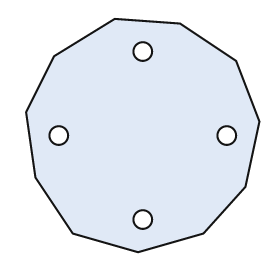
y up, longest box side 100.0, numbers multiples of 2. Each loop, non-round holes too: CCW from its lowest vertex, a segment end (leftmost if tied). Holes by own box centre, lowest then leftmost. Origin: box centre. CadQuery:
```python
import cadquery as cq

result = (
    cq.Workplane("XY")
    .moveTo(-2.0, -50.0)
    .lineTo(26.0, -42.0)
    .lineTo(44.0, -22.0)
    .lineTo(50.0, 6.0)
    .lineTo(40.0, 32.0)
    .lineTo(16.0, 48.0)
    .lineTo(-12.0, 50.0)
    .lineTo(-38.0, 34.0)
    .lineTo(-50.0, 10.0)
    .lineTo(-46.0, -18.0)
    .lineTo(-30.0, -42.0)
    .close()
    .moveTo(0.0, -36.0)
    .circle(4.0)
    .moveTo(-36.0, 0.0)
    .circle(4.0)
    .moveTo(36.0, 0.0)
    .circle(4.0)
    .moveTo(0.0, 36.0)
    .circle(4.0)
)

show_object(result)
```